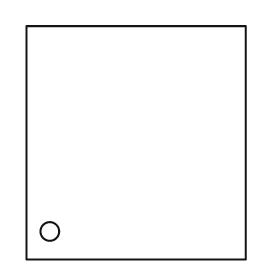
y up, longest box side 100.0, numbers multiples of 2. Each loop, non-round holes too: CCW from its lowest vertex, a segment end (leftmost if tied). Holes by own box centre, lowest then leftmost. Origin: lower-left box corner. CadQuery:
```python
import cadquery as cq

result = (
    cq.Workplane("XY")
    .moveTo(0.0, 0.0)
    .lineTo(94.0, 0.0)
    .lineTo(94.0, 100.0)
    .lineTo(0.0, 100.0)
    .close()
    .moveTo(10.0, 12.0)
    .circle(4.0)
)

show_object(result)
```